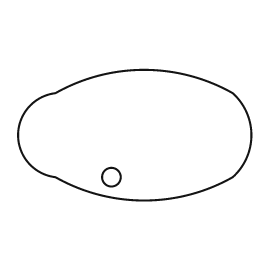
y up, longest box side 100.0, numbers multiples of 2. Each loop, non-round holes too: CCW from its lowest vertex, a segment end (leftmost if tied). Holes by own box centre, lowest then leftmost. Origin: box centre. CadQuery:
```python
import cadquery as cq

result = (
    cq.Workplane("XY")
    .moveTo(-34.0, -18.0)
    .threePointArc((4.0, -28.0), (42.0, -18.0))
    .threePointArc((50.0, 0.0), (42.0, 18.0))
    .threePointArc((4.0, 28.0), (-34.0, 18.0))
    .threePointArc((-50.0, 0.0), (-34.0, -18.0))
    .close()
    .moveTo(-10.0, -18.0)
    .circle(4.0)
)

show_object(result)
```